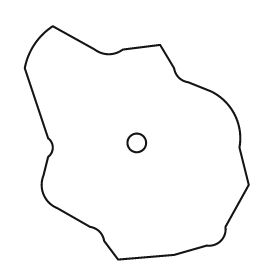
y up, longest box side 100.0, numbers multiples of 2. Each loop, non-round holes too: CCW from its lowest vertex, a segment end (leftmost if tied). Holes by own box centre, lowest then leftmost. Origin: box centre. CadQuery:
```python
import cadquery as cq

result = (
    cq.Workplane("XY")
    .moveTo(-8.0, -50.0)
    .lineTo(16.0, -48.0)
    .lineTo(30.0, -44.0)
    .threePointArc((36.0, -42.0), (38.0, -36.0))
    .lineTo(48.0, -18.0)
    .lineTo(44.0, -2.0)
    .threePointArc((42.0, 12.0), (32.0, 22.0))
    .lineTo(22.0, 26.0)
    .threePointArc((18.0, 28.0), (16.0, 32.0))
    .lineTo(10.0, 42.0)
    .lineTo(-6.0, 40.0)
    .threePointArc((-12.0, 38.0), (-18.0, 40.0))
    .lineTo(-36.0, 50.0)
    .threePointArc((-44.0, 42.0), (-48.0, 32.0))
    .lineTo(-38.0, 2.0)
    .threePointArc((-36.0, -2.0), (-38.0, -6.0))
    .lineTo(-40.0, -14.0)
    .threePointArc((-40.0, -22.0), (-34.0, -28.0))
    .lineTo(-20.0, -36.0)
    .threePointArc((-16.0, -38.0), (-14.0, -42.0))
    .close()
    .moveTo(0.0, 0.0)
    .circle(4.0)
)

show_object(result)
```